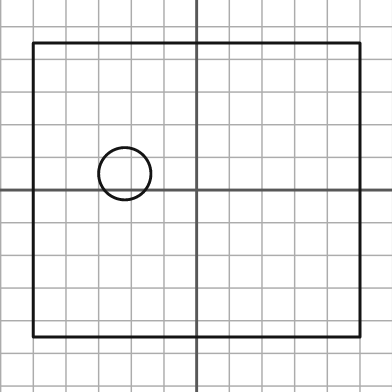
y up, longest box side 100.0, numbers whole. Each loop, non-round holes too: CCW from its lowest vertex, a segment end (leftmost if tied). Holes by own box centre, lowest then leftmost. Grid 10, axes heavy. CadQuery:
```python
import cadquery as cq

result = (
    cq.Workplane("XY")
    .moveTo(-50.0, -45.0)
    .lineTo(50.0, -45.0)
    .lineTo(50.0, 45.0)
    .lineTo(-50.0, 45.0)
    .close()
    .moveTo(-22.0, 5.0)
    .circle(8.0)
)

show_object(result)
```